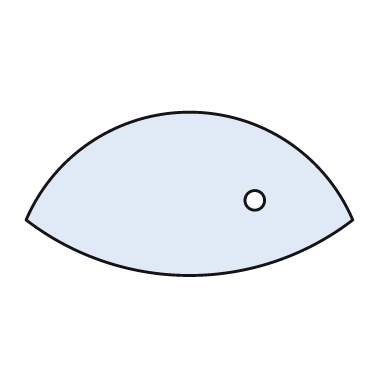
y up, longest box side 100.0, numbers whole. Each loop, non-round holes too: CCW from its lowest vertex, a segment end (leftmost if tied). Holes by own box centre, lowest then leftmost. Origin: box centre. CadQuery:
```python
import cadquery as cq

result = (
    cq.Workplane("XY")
    .moveTo(-50.0, -8.0)
    .threePointArc((0.0, -25.0), (50.0, -8.0))
    .threePointArc((0.0, 25.0), (-50.0, -8.0))
    .close()
    .moveTo(20.0, -2.0)
    .circle(3.0)
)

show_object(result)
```